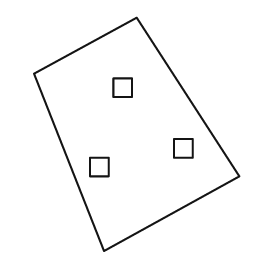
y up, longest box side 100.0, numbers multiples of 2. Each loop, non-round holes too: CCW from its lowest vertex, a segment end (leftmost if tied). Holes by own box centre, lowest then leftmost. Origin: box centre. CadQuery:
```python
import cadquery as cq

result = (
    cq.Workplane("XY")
    .moveTo(-14.0, -50.0)
    .lineTo(44.0, -18.0)
    .lineTo(0.0, 50.0)
    .lineTo(-44.0, 26.0)
    .close()
    .moveTo(-20.0, -18.0)
    .lineTo(-12.0, -18.0)
    .lineTo(-12.0, -10.0)
    .lineTo(-20.0, -10.0)
    .close()
    .moveTo(16.0, -10.0)
    .lineTo(24.0, -10.0)
    .lineTo(24.0, -2.0)
    .lineTo(16.0, -2.0)
    .close()
    .moveTo(-10.0, 16.0)
    .lineTo(-2.0, 16.0)
    .lineTo(-2.0, 24.0)
    .lineTo(-10.0, 24.0)
    .close()
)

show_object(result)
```